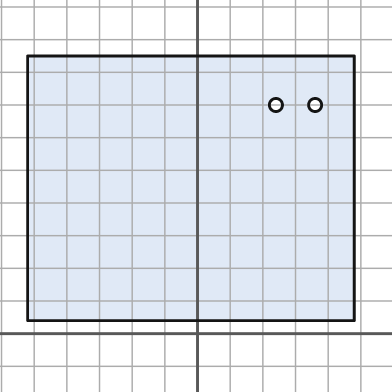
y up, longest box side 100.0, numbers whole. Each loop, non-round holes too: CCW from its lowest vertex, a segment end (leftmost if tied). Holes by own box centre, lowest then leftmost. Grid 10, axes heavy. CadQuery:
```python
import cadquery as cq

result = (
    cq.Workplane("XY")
    .moveTo(-52.0, 4.0)
    .lineTo(48.0, 4.0)
    .lineTo(48.0, 85.0)
    .lineTo(-52.0, 85.0)
    .close()
    .moveTo(24.0, 70.0)
    .circle(2.0)
    .moveTo(36.0, 70.0)
    .circle(2.0)
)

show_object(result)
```